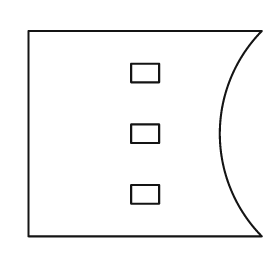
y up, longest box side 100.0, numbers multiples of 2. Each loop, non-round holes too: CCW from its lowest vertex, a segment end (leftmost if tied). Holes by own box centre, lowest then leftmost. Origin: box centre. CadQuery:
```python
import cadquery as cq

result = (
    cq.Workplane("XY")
    .moveTo(-50.0, -44.0)
    .lineTo(50.0, -44.0)
    .threePointArc((32.0, 0.0), (50.0, 44.0))
    .lineTo(-50.0, 44.0)
    .close()
    .moveTo(-6.0, -30.0)
    .lineTo(6.0, -30.0)
    .lineTo(6.0, -22.0)
    .lineTo(-6.0, -22.0)
    .close()
    .moveTo(-6.0, -4.0)
    .lineTo(6.0, -4.0)
    .lineTo(6.0, 4.0)
    .lineTo(-6.0, 4.0)
    .close()
    .moveTo(-6.0, 22.0)
    .lineTo(6.0, 22.0)
    .lineTo(6.0, 30.0)
    .lineTo(-6.0, 30.0)
    .close()
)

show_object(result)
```